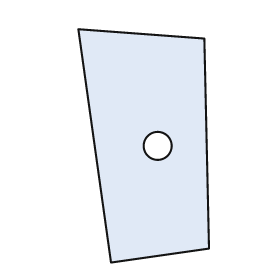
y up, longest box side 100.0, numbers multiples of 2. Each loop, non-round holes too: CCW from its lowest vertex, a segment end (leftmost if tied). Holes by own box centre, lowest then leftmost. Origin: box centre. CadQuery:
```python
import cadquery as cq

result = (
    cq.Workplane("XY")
    .moveTo(-14.0, -50.0)
    .lineTo(28.0, -44.0)
    .lineTo(26.0, 46.0)
    .lineTo(-28.0, 50.0)
    .close()
    .moveTo(6.0, 0.0)
    .circle(6.0)
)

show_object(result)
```